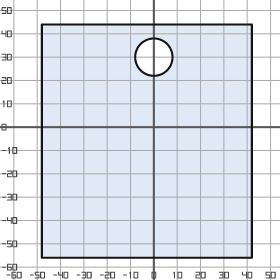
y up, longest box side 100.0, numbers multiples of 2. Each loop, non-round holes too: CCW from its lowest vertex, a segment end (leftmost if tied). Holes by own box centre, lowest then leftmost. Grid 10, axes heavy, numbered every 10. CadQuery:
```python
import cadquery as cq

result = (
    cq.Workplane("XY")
    .moveTo(-48.0, -56.0)
    .lineTo(42.0, -56.0)
    .lineTo(42.0, 44.0)
    .lineTo(-48.0, 44.0)
    .close()
    .moveTo(0.0, 30.0)
    .circle(8.0)
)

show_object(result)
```